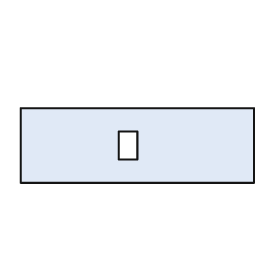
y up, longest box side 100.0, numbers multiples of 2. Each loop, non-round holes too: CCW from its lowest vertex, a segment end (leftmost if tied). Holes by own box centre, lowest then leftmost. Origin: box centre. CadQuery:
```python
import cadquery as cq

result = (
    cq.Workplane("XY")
    .moveTo(-50.0, -16.0)
    .lineTo(50.0, -16.0)
    .lineTo(50.0, 16.0)
    .lineTo(-50.0, 16.0)
    .close()
    .moveTo(-8.0, -6.0)
    .lineTo(0.0, -6.0)
    .lineTo(0.0, 6.0)
    .lineTo(-8.0, 6.0)
    .close()
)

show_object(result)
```